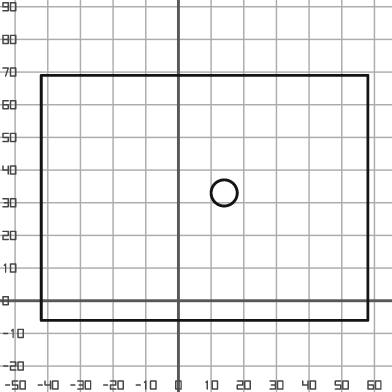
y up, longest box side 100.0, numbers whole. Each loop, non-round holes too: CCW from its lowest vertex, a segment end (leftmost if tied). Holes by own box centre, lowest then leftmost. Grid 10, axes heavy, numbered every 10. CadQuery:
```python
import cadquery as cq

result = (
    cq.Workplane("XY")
    .moveTo(-42.0, -6.0)
    .lineTo(58.0, -6.0)
    .lineTo(58.0, 69.0)
    .lineTo(-42.0, 69.0)
    .close()
    .moveTo(14.0, 33.0)
    .circle(4.0)
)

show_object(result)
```